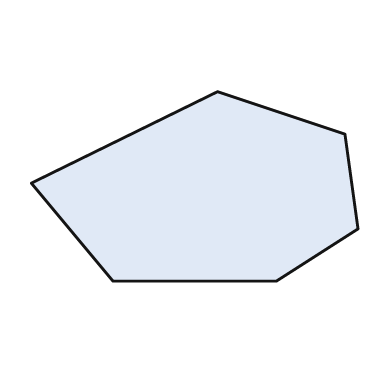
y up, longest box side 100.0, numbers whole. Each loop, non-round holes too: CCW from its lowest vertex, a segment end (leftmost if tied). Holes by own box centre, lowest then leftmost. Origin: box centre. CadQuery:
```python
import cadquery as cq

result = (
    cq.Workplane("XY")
    .moveTo(-25.0, -29.0)
    .lineTo(25.0, -29.0)
    .lineTo(50.0, -13.0)
    .lineTo(46.0, 16.0)
    .lineTo(7.0, 29.0)
    .lineTo(-50.0, 1.0)
    .close()
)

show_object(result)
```